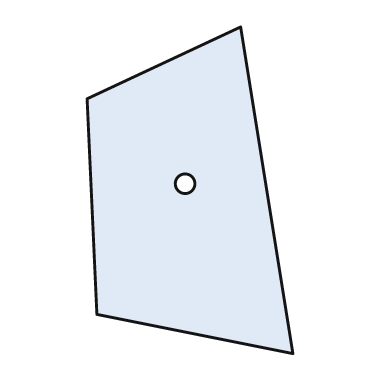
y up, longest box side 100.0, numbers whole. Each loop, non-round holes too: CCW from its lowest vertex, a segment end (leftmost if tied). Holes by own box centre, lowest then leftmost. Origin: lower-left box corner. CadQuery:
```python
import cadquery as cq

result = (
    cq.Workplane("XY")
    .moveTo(63.0, 0.0)
    .lineTo(47.0, 100.0)
    .lineTo(0.0, 78.0)
    .lineTo(3.0, 12.0)
    .close()
    .moveTo(30.0, 52.0)
    .circle(3.0)
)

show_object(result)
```